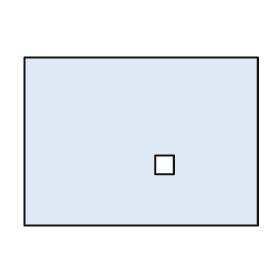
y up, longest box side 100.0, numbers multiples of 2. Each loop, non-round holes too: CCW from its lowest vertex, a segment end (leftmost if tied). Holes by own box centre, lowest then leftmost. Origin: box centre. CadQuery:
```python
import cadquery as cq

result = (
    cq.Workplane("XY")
    .moveTo(-50.0, -36.0)
    .lineTo(50.0, -36.0)
    .lineTo(50.0, 36.0)
    .lineTo(-50.0, 36.0)
    .close()
    .moveTo(6.0, -14.0)
    .lineTo(14.0, -14.0)
    .lineTo(14.0, -6.0)
    .lineTo(6.0, -6.0)
    .close()
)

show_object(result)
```